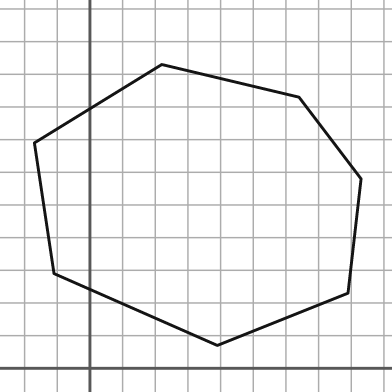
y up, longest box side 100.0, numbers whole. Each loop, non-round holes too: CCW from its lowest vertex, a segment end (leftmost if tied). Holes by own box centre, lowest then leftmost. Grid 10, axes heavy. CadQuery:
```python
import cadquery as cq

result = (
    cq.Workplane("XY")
    .moveTo(39.0, 7.0)
    .lineTo(79.0, 23.0)
    .lineTo(83.0, 58.0)
    .lineTo(64.0, 83.0)
    .lineTo(22.0, 93.0)
    .lineTo(-17.0, 69.0)
    .lineTo(-11.0, 29.0)
    .close()
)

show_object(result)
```